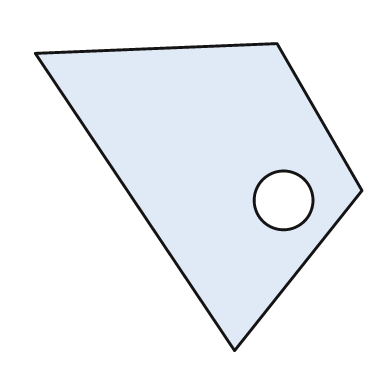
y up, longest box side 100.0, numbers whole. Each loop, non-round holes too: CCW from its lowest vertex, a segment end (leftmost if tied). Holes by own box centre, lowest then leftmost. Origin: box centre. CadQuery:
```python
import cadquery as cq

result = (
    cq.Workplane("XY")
    .moveTo(11.0, -47.0)
    .lineTo(50.0, 2.0)
    .lineTo(24.0, 47.0)
    .lineTo(-50.0, 44.0)
    .close()
    .moveTo(26.0, -1.0)
    .circle(9.0)
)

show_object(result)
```